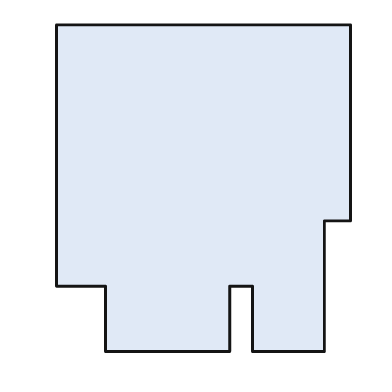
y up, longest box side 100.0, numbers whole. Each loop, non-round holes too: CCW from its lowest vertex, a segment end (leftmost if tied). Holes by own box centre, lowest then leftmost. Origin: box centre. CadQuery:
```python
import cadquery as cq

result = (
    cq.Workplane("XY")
    .moveTo(-30.0, -50.0)
    .lineTo(8.0, -50.0)
    .lineTo(8.0, -30.0)
    .lineTo(15.0, -30.0)
    .lineTo(15.0, -50.0)
    .lineTo(37.0, -50.0)
    .lineTo(37.0, -10.0)
    .lineTo(45.0, -10.0)
    .lineTo(45.0, 50.0)
    .lineTo(-45.0, 50.0)
    .lineTo(-45.0, -30.0)
    .lineTo(-30.0, -30.0)
    .close()
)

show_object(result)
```